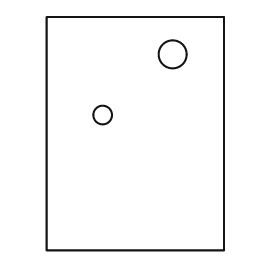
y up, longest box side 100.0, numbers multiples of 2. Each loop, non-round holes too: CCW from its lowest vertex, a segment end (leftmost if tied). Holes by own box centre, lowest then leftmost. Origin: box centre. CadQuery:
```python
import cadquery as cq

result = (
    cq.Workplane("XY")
    .moveTo(-38.0, -50.0)
    .lineTo(38.0, -50.0)
    .lineTo(38.0, 50.0)
    .lineTo(-38.0, 50.0)
    .close()
    .moveTo(-14.0, 8.0)
    .circle(4.0)
    .moveTo(16.0, 34.0)
    .circle(6.0)
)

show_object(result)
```